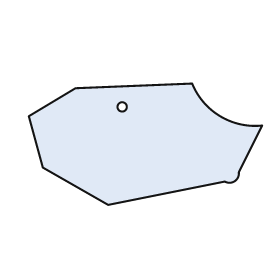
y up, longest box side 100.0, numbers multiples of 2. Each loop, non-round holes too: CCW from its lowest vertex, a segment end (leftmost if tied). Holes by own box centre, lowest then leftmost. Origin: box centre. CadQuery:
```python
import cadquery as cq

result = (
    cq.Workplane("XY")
    .moveTo(-16.0, -26.0)
    .lineTo(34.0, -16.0)
    .threePointArc((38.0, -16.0), (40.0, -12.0))
    .lineTo(50.0, 8.0)
    .threePointArc((32.0, 12.0), (20.0, 26.0))
    .lineTo(-30.0, 24.0)
    .lineTo(-50.0, 12.0)
    .lineTo(-44.0, -10.0)
    .close()
    .moveTo(-10.0, 16.0)
    .circle(2.0)
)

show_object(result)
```